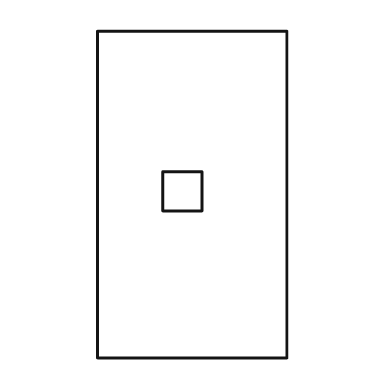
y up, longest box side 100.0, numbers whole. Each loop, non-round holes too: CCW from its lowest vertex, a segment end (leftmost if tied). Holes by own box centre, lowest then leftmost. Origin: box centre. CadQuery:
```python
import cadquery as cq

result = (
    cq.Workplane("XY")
    .moveTo(-29.0, -50.0)
    .lineTo(29.0, -50.0)
    .lineTo(29.0, 50.0)
    .lineTo(-29.0, 50.0)
    .close()
    .moveTo(-9.0, -5.0)
    .lineTo(3.0, -5.0)
    .lineTo(3.0, 7.0)
    .lineTo(-9.0, 7.0)
    .close()
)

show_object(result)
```